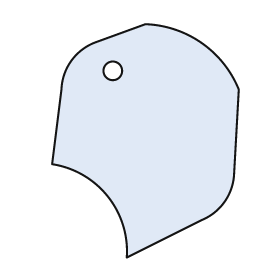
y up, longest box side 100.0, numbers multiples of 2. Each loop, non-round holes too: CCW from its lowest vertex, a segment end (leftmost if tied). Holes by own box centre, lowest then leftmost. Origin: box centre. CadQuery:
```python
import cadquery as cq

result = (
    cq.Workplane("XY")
    .moveTo(-8.0, -50.0)
    .lineTo(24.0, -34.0)
    .threePointArc((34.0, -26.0), (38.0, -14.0))
    .lineTo(40.0, 22.0)
    .threePointArc((24.0, 42.0), (0.0, 50.0))
    .lineTo(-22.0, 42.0)
    .threePointArc((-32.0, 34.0), (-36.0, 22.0))
    .lineTo(-40.0, -10.0)
    .threePointArc((-16.0, -24.0), (-8.0, -50.0))
    .close()
    .moveTo(-14.0, 30.0)
    .circle(4.0)
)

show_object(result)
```